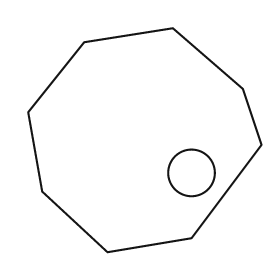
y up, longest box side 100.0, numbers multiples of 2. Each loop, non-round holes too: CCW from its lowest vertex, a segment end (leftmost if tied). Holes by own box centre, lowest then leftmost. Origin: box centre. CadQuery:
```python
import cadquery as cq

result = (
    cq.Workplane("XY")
    .moveTo(-16.0, -48.0)
    .lineTo(20.0, -42.0)
    .lineTo(50.0, -2.0)
    .lineTo(42.0, 22.0)
    .lineTo(12.0, 48.0)
    .lineTo(-26.0, 42.0)
    .lineTo(-50.0, 12.0)
    .lineTo(-44.0, -22.0)
    .close()
    .moveTo(20.0, -14.0)
    .circle(10.0)
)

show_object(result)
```